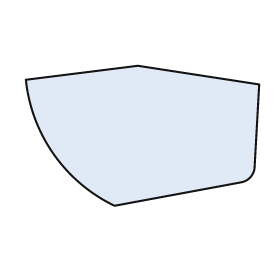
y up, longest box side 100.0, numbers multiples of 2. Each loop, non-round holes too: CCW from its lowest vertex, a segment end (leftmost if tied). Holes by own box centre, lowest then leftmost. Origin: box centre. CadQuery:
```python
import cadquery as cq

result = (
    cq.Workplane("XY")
    .moveTo(-12.0, -30.0)
    .lineTo(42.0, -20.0)
    .threePointArc((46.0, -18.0), (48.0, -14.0))
    .lineTo(50.0, 22.0)
    .lineTo(-2.0, 30.0)
    .lineTo(-50.0, 24.0)
    .threePointArc((-38.0, -8.0), (-12.0, -30.0))
    .close()
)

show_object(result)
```